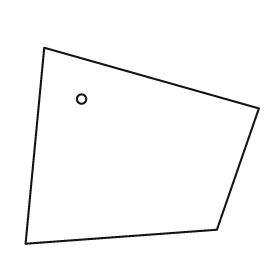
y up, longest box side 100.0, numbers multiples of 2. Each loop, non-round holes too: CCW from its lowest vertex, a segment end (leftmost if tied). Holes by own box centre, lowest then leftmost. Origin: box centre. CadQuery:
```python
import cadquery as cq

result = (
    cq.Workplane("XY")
    .moveTo(-50.0, -42.0)
    .lineTo(32.0, -36.0)
    .lineTo(50.0, 16.0)
    .lineTo(-42.0, 42.0)
    .close()
    .moveTo(-26.0, 20.0)
    .circle(2.0)
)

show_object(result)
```